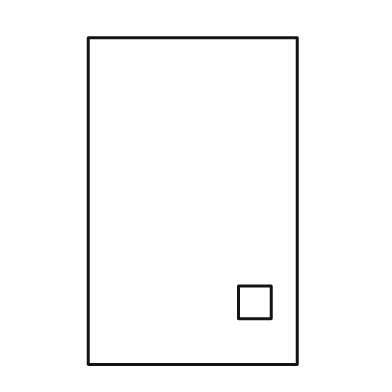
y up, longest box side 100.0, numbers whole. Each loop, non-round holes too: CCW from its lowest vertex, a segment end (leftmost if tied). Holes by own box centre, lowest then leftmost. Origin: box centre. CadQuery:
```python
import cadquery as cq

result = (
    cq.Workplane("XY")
    .moveTo(-32.0, -50.0)
    .lineTo(32.0, -50.0)
    .lineTo(32.0, 50.0)
    .lineTo(-32.0, 50.0)
    .close()
    .moveTo(14.0, -36.0)
    .lineTo(24.0, -36.0)
    .lineTo(24.0, -26.0)
    .lineTo(14.0, -26.0)
    .close()
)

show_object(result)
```